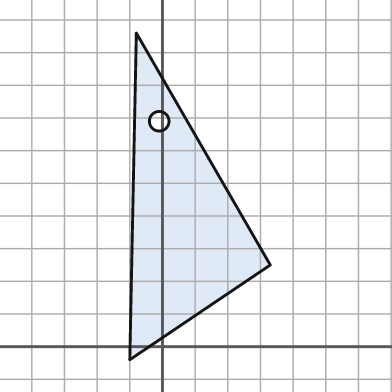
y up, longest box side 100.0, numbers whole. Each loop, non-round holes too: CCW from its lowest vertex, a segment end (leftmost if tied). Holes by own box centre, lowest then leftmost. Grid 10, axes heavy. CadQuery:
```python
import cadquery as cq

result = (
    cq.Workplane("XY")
    .moveTo(-10.0, -4.0)
    .lineTo(33.0, 25.0)
    .lineTo(-8.0, 96.0)
    .close()
    .moveTo(-1.0, 69.0)
    .circle(3.0)
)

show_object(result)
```